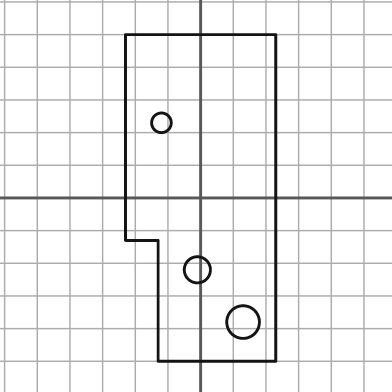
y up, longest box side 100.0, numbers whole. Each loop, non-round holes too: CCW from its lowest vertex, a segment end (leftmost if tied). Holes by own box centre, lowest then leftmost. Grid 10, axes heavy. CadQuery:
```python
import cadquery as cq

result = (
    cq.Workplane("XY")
    .moveTo(-13.0, -50.0)
    .lineTo(23.0, -50.0)
    .lineTo(23.0, 50.0)
    .lineTo(-23.0, 50.0)
    .lineTo(-23.0, -13.0)
    .lineTo(-13.0, -13.0)
    .close()
    .moveTo(13.0, -38.0)
    .circle(5.0)
    .moveTo(-1.0, -22.0)
    .circle(4.0)
    .moveTo(-12.0, 23.0)
    .circle(3.0)
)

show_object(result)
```